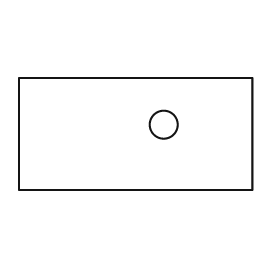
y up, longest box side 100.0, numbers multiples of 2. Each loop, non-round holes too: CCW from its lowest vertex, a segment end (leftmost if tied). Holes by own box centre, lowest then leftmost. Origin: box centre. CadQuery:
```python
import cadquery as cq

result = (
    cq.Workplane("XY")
    .moveTo(-50.0, -24.0)
    .lineTo(50.0, -24.0)
    .lineTo(50.0, 24.0)
    .lineTo(-50.0, 24.0)
    .close()
    .moveTo(12.0, 4.0)
    .circle(6.0)
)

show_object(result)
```